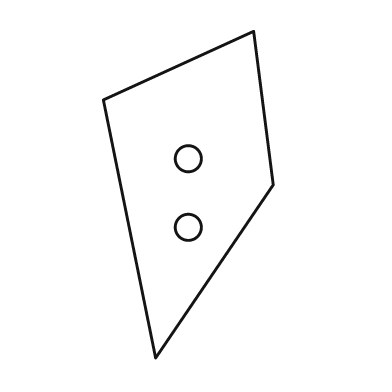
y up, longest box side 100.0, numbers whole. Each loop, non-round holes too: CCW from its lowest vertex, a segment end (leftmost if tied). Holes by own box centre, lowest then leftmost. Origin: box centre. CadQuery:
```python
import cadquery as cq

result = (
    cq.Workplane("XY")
    .moveTo(-10.0, -50.0)
    .lineTo(26.0, 3.0)
    .lineTo(20.0, 50.0)
    .lineTo(-26.0, 29.0)
    .close()
    .moveTo(0.0, -10.0)
    .circle(4.0)
    .moveTo(0.0, 11.0)
    .circle(4.0)
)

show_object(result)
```